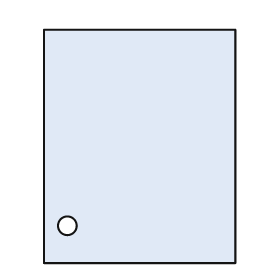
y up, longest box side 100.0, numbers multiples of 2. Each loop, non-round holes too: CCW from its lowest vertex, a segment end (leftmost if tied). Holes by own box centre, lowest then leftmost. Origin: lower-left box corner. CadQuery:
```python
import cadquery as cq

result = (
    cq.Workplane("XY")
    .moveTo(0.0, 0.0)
    .lineTo(82.0, 0.0)
    .lineTo(82.0, 100.0)
    .lineTo(0.0, 100.0)
    .close()
    .moveTo(10.0, 16.0)
    .circle(4.0)
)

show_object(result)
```